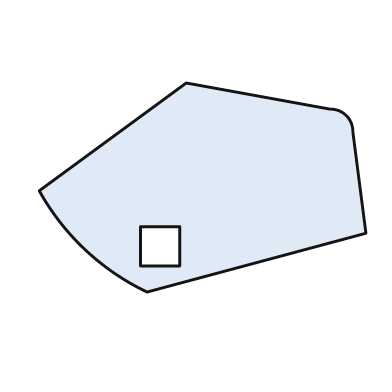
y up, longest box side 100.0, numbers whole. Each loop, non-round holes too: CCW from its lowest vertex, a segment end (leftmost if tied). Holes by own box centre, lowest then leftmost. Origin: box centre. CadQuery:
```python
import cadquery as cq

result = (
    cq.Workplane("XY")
    .moveTo(-17.0, -32.0)
    .lineTo(50.0, -14.0)
    .lineTo(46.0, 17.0)
    .threePointArc((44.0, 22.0), (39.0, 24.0))
    .lineTo(-5.0, 32.0)
    .lineTo(-50.0, -1.0)
    .threePointArc((-36.0, -19.0), (-17.0, -32.0))
    .close()
    .moveTo(-19.0, -24.0)
    .lineTo(-7.0, -24.0)
    .lineTo(-7.0, -12.0)
    .lineTo(-19.0, -12.0)
    .close()
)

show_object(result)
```